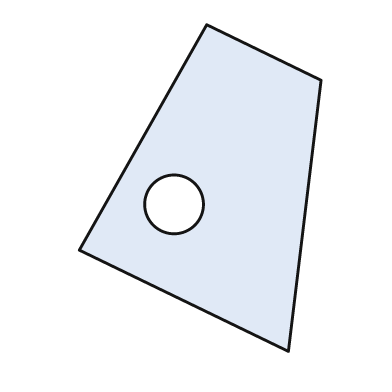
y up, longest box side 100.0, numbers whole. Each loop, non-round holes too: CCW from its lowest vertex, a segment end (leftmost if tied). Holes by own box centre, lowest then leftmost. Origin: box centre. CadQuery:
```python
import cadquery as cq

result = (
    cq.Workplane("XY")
    .moveTo(27.0, -50.0)
    .lineTo(37.0, 33.0)
    .lineTo(2.0, 50.0)
    .lineTo(-37.0, -19.0)
    .close()
    .moveTo(-8.0, -5.0)
    .circle(9.0)
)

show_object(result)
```